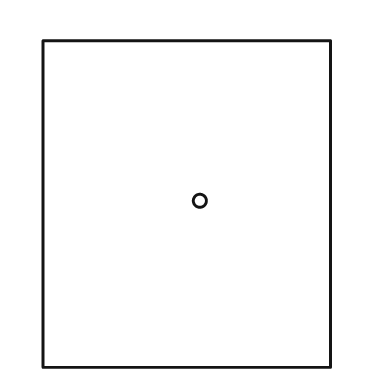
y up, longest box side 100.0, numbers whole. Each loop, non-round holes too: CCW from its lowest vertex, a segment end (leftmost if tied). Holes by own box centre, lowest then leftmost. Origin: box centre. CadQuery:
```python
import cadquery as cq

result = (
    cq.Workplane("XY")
    .moveTo(-44.0, -50.0)
    .lineTo(44.0, -50.0)
    .lineTo(44.0, 50.0)
    .lineTo(-44.0, 50.0)
    .close()
    .moveTo(4.0, 1.0)
    .circle(2.0)
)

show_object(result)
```